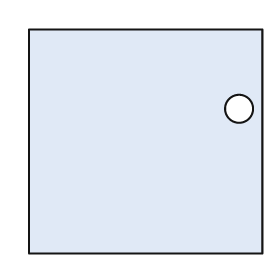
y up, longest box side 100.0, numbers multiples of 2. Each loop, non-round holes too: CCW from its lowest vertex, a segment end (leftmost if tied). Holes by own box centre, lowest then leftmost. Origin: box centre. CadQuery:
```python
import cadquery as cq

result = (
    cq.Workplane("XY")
    .moveTo(-50.0, -48.0)
    .lineTo(50.0, -48.0)
    .lineTo(50.0, 48.0)
    .lineTo(-50.0, 48.0)
    .close()
    .moveTo(40.0, 14.0)
    .circle(6.0)
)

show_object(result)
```